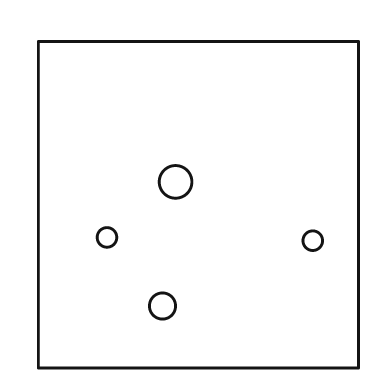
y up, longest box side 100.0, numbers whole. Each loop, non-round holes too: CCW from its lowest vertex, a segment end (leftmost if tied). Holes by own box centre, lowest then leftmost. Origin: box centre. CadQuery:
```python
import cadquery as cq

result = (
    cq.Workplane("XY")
    .moveTo(-49.0, -50.0)
    .lineTo(49.0, -50.0)
    .lineTo(49.0, 50.0)
    .lineTo(-49.0, 50.0)
    .close()
    .moveTo(-11.0, -31.0)
    .circle(4.0)
    .moveTo(35.0, -11.0)
    .circle(3.0)
    .moveTo(-28.0, -10.0)
    .circle(3.0)
    .moveTo(-7.0, 7.0)
    .circle(5.0)
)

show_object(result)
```